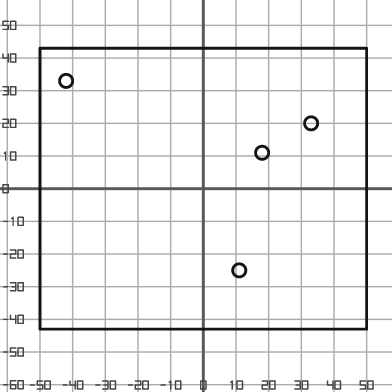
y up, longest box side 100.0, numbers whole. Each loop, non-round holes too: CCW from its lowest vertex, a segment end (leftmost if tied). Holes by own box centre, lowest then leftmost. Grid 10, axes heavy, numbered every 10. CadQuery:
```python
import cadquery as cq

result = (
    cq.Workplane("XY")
    .moveTo(-50.0, -43.0)
    .lineTo(50.0, -43.0)
    .lineTo(50.0, 43.0)
    .lineTo(-50.0, 43.0)
    .close()
    .moveTo(11.0, -25.0)
    .circle(2.0)
    .moveTo(18.0, 11.0)
    .circle(2.0)
    .moveTo(33.0, 20.0)
    .circle(2.0)
    .moveTo(-42.0, 33.0)
    .circle(2.0)
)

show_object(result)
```